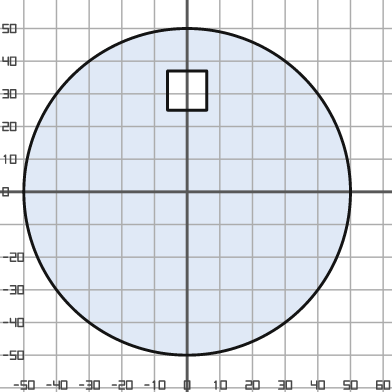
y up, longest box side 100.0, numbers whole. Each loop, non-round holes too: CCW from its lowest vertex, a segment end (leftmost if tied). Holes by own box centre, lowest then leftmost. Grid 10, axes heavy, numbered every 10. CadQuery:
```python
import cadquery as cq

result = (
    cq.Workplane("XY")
    .moveTo(0.0, 0.0)
    .circle(50.0)
    .moveTo(-6.0, 25.0)
    .lineTo(6.0, 25.0)
    .lineTo(6.0, 37.0)
    .lineTo(-6.0, 37.0)
    .close()
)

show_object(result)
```